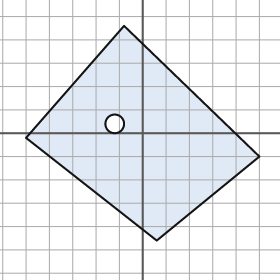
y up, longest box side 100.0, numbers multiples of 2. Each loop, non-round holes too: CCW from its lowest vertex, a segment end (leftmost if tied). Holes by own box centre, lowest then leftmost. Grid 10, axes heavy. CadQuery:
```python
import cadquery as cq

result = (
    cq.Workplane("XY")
    .moveTo(6.0, -46.0)
    .lineTo(50.0, -10.0)
    .lineTo(-8.0, 46.0)
    .lineTo(-50.0, -2.0)
    .close()
    .moveTo(-12.0, 4.0)
    .circle(4.0)
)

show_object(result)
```